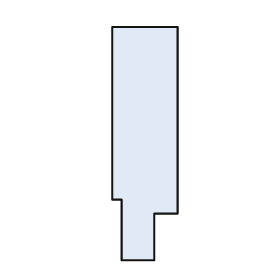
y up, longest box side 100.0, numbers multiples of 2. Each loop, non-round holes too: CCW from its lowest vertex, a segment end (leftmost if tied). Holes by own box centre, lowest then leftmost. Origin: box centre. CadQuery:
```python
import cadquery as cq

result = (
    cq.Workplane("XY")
    .moveTo(-10.0, -50.0)
    .lineTo(4.0, -50.0)
    .lineTo(4.0, -30.0)
    .lineTo(14.0, -30.0)
    .lineTo(14.0, 50.0)
    .lineTo(-14.0, 50.0)
    .lineTo(-14.0, -24.0)
    .lineTo(-10.0, -24.0)
    .close()
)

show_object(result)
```